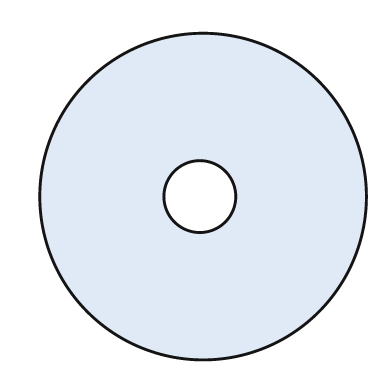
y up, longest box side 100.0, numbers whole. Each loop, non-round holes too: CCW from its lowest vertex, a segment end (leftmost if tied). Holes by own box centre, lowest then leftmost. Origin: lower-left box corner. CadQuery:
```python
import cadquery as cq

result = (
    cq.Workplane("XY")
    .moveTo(50.0, 50.0)
    .circle(50.0)
    .moveTo(49.0, 50.0)
    .circle(11.0)
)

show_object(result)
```